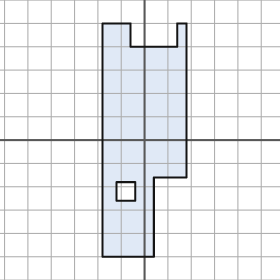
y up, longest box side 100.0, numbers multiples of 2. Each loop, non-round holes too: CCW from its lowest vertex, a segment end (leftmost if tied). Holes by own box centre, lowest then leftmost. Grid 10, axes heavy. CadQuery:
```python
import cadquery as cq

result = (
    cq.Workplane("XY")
    .moveTo(-18.0, -50.0)
    .lineTo(4.0, -50.0)
    .lineTo(4.0, -16.0)
    .lineTo(18.0, -16.0)
    .lineTo(18.0, 50.0)
    .lineTo(14.0, 50.0)
    .lineTo(14.0, 40.0)
    .lineTo(-6.0, 40.0)
    .lineTo(-6.0, 50.0)
    .lineTo(-18.0, 50.0)
    .close()
    .moveTo(-12.0, -26.0)
    .lineTo(-4.0, -26.0)
    .lineTo(-4.0, -18.0)
    .lineTo(-12.0, -18.0)
    .close()
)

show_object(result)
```